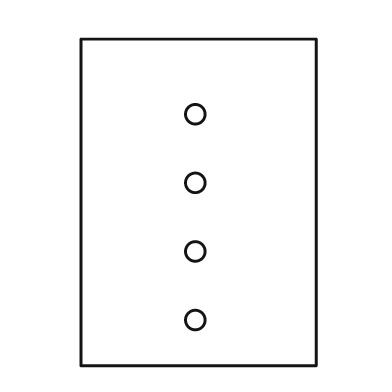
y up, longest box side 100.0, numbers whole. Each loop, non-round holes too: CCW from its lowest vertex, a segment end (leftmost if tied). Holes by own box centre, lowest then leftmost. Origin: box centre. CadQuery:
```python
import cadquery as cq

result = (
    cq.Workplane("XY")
    .moveTo(-36.0, -50.0)
    .lineTo(36.0, -50.0)
    .lineTo(36.0, 50.0)
    .lineTo(-36.0, 50.0)
    .close()
    .moveTo(-1.0, -36.0)
    .circle(3.0)
    .moveTo(-1.0, -15.0)
    .circle(3.0)
    .moveTo(-1.0, 6.0)
    .circle(3.0)
    .moveTo(-1.0, 27.0)
    .circle(3.0)
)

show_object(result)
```